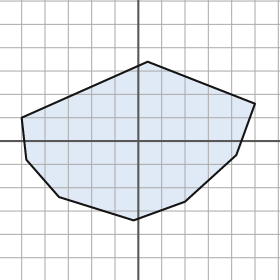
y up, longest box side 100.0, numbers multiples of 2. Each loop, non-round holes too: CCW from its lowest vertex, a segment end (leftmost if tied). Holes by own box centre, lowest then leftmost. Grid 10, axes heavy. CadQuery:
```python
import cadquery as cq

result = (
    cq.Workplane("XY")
    .moveTo(-2.0, -34.0)
    .lineTo(20.0, -26.0)
    .lineTo(42.0, -6.0)
    .lineTo(50.0, 16.0)
    .lineTo(4.0, 34.0)
    .lineTo(-50.0, 10.0)
    .lineTo(-48.0, -8.0)
    .lineTo(-34.0, -24.0)
    .close()
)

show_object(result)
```